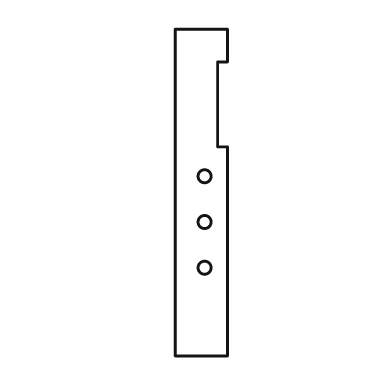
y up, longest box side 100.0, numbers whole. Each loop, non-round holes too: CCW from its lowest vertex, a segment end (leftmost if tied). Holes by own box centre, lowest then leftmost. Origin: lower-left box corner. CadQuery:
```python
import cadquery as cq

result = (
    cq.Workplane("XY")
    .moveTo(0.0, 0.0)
    .lineTo(16.0, 0.0)
    .lineTo(16.0, 64.0)
    .lineTo(13.0, 64.0)
    .lineTo(13.0, 90.0)
    .lineTo(16.0, 90.0)
    .lineTo(16.0, 100.0)
    .lineTo(0.0, 100.0)
    .close()
    .moveTo(9.0, 27.0)
    .circle(2.0)
    .moveTo(9.0, 41.0)
    .circle(2.0)
    .moveTo(9.0, 55.0)
    .circle(2.0)
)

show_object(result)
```